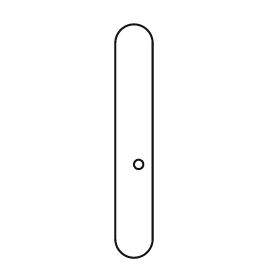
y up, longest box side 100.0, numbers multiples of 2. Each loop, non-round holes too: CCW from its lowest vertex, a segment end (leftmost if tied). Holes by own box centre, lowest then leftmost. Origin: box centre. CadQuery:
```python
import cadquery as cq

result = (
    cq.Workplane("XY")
    .moveTo(-8.0, -42.0)
    .threePointArc((0.0, -50.0), (8.0, -42.0))
    .lineTo(8.0, 42.0)
    .threePointArc((0.0, 50.0), (-8.0, 42.0))
    .close()
    .moveTo(2.0, -10.0)
    .circle(2.0)
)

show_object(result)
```